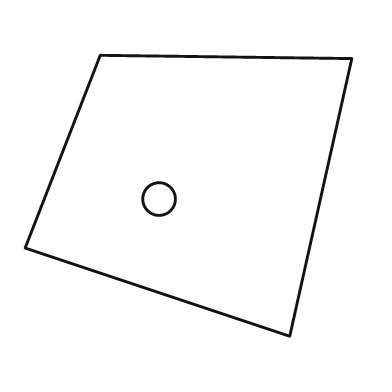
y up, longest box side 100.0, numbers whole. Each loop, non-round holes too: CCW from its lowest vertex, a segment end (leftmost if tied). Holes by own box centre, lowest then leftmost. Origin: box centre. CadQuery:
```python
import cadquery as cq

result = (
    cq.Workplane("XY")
    .moveTo(31.0, -43.0)
    .lineTo(50.0, 42.0)
    .lineTo(-27.0, 43.0)
    .lineTo(-50.0, -16.0)
    .close()
    .moveTo(-9.0, -1.0)
    .circle(5.0)
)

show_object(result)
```